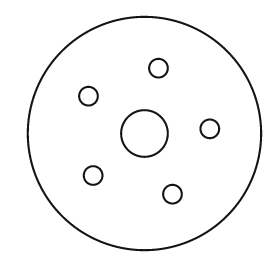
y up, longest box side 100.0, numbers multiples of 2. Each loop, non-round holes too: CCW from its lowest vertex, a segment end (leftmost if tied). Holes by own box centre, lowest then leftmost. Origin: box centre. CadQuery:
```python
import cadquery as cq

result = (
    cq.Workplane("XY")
    .moveTo(0.0, 0.0)
    .circle(50.0)
    .moveTo(12.0, -26.0)
    .circle(4.0)
    .moveTo(-22.0, -18.0)
    .circle(4.0)
    .moveTo(0.0, 0.0)
    .circle(10.0)
    .moveTo(28.0, 2.0)
    .circle(4.0)
    .moveTo(-24.0, 16.0)
    .circle(4.0)
    .moveTo(6.0, 28.0)
    .circle(4.0)
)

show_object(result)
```